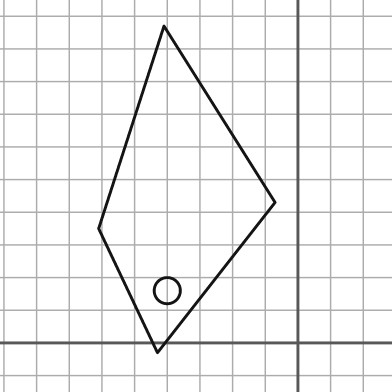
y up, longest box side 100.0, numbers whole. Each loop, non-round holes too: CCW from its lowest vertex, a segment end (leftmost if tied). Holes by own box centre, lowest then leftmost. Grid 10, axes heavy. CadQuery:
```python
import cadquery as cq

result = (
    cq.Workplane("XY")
    .moveTo(-43.0, -3.0)
    .lineTo(-7.0, 43.0)
    .lineTo(-41.0, 97.0)
    .lineTo(-61.0, 35.0)
    .close()
    .moveTo(-40.0, 16.0)
    .circle(4.0)
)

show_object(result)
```